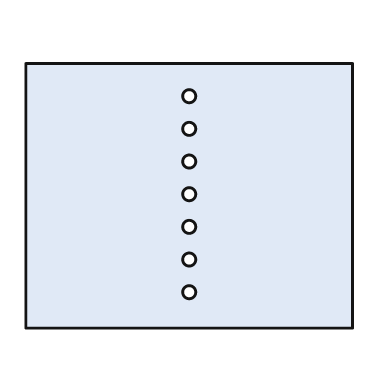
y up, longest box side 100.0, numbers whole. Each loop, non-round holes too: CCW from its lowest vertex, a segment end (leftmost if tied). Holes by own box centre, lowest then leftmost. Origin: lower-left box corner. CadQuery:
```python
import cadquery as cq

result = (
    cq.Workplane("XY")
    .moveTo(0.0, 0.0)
    .lineTo(100.0, 0.0)
    .lineTo(100.0, 81.0)
    .lineTo(0.0, 81.0)
    .close()
    .moveTo(50.0, 11.0)
    .circle(2.0)
    .moveTo(50.0, 21.0)
    .circle(2.0)
    .moveTo(50.0, 31.0)
    .circle(2.0)
    .moveTo(50.0, 41.0)
    .circle(2.0)
    .moveTo(50.0, 51.0)
    .circle(2.0)
    .moveTo(50.0, 61.0)
    .circle(2.0)
    .moveTo(50.0, 71.0)
    .circle(2.0)
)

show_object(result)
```